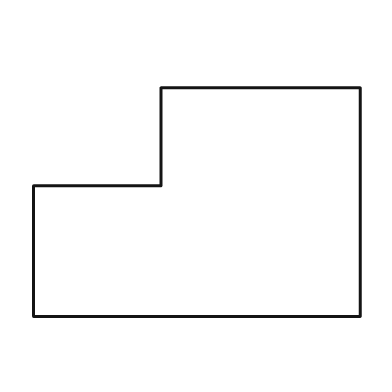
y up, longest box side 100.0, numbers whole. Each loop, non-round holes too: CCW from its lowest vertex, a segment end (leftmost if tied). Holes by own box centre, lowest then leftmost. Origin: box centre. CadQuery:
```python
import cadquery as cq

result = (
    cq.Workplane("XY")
    .moveTo(-50.0, -35.0)
    .lineTo(50.0, -35.0)
    .lineTo(50.0, 35.0)
    .lineTo(-11.0, 35.0)
    .lineTo(-11.0, 5.0)
    .lineTo(-50.0, 5.0)
    .close()
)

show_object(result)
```